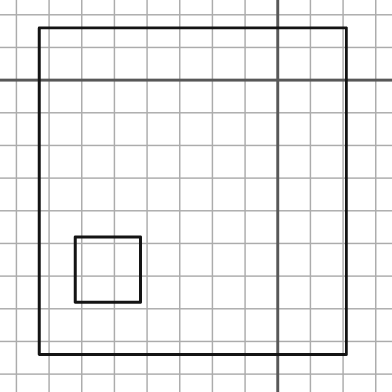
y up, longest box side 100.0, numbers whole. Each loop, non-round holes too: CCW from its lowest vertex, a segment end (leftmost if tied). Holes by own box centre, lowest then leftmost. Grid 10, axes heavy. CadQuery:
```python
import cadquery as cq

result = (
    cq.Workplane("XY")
    .moveTo(-73.0, -84.0)
    .lineTo(21.0, -84.0)
    .lineTo(21.0, 16.0)
    .lineTo(-73.0, 16.0)
    .close()
    .moveTo(-62.0, -68.0)
    .lineTo(-42.0, -68.0)
    .lineTo(-42.0, -48.0)
    .lineTo(-62.0, -48.0)
    .close()
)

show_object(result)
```